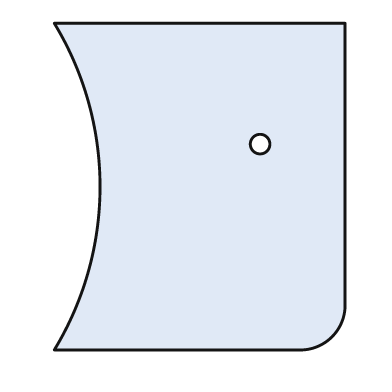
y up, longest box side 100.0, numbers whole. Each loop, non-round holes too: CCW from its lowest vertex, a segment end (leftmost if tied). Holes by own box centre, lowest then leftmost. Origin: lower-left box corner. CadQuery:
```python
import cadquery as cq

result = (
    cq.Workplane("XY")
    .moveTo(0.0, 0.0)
    .lineTo(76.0, 0.0)
    .threePointArc((85.0, 4.0), (89.0, 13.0))
    .lineTo(89.0, 100.0)
    .lineTo(0.0, 100.0)
    .threePointArc((14.0, 50.0), (0.0, 0.0))
    .close()
    .moveTo(63.0, 63.0)
    .circle(3.0)
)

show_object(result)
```